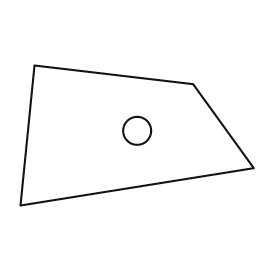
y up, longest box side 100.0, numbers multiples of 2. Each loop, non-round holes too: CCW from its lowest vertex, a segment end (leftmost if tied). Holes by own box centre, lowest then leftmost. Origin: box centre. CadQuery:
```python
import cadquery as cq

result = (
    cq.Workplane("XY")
    .moveTo(-50.0, -30.0)
    .lineTo(50.0, -14.0)
    .lineTo(24.0, 22.0)
    .lineTo(-44.0, 30.0)
    .close()
    .moveTo(0.0, 2.0)
    .circle(6.0)
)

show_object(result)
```